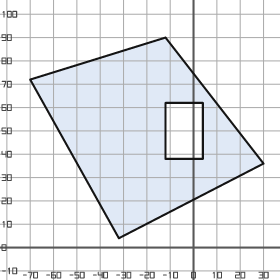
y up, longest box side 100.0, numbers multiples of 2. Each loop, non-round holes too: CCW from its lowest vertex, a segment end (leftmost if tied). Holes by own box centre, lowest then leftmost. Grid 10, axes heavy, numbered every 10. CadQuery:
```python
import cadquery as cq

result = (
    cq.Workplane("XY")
    .moveTo(-32.0, 4.0)
    .lineTo(30.0, 36.0)
    .lineTo(-12.0, 90.0)
    .lineTo(-70.0, 72.0)
    .close()
    .moveTo(-12.0, 38.0)
    .lineTo(4.0, 38.0)
    .lineTo(4.0, 62.0)
    .lineTo(-12.0, 62.0)
    .close()
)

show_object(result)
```